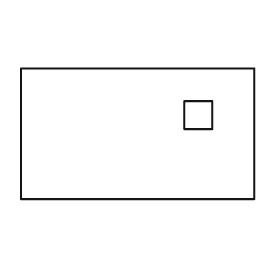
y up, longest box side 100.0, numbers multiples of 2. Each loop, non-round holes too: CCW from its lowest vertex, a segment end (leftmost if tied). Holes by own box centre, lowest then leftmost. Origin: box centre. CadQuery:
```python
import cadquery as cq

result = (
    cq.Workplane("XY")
    .moveTo(-50.0, -28.0)
    .lineTo(50.0, -28.0)
    .lineTo(50.0, 28.0)
    .lineTo(-50.0, 28.0)
    .close()
    .moveTo(20.0, 2.0)
    .lineTo(32.0, 2.0)
    .lineTo(32.0, 14.0)
    .lineTo(20.0, 14.0)
    .close()
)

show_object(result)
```